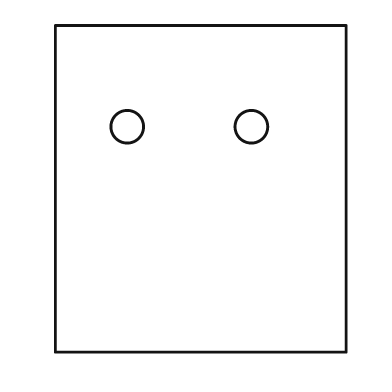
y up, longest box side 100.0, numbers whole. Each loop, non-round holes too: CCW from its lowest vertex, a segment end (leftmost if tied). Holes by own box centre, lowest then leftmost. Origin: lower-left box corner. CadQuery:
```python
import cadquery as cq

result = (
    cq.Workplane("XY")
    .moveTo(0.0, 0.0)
    .lineTo(89.0, 0.0)
    .lineTo(89.0, 100.0)
    .lineTo(0.0, 100.0)
    .close()
    .moveTo(22.0, 69.0)
    .circle(5.0)
    .moveTo(60.0, 69.0)
    .circle(5.0)
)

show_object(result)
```